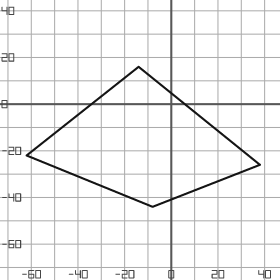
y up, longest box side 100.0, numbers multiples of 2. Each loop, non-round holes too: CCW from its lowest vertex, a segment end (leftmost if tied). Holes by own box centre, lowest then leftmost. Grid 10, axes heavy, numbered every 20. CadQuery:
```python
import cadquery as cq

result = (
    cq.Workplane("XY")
    .moveTo(-8.0, -44.0)
    .lineTo(38.0, -26.0)
    .lineTo(-14.0, 16.0)
    .lineTo(-62.0, -22.0)
    .close()
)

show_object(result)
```